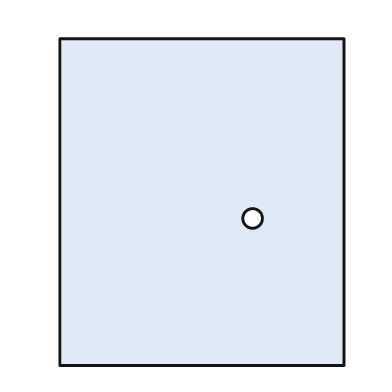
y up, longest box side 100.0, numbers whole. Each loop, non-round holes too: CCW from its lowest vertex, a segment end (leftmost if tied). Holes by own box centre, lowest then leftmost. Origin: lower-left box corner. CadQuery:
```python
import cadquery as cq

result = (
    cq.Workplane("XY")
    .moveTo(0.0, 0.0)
    .lineTo(87.0, 0.0)
    .lineTo(87.0, 100.0)
    .lineTo(0.0, 100.0)
    .close()
    .moveTo(59.0, 45.0)
    .circle(3.0)
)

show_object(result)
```